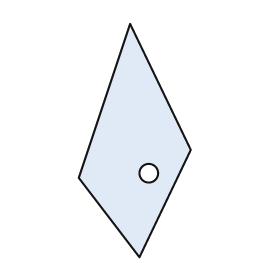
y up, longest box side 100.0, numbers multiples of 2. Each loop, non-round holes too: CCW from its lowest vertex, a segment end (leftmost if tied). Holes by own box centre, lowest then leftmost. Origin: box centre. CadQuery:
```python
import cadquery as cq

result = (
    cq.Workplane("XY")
    .moveTo(2.0, -50.0)
    .lineTo(24.0, -4.0)
    .lineTo(-2.0, 50.0)
    .lineTo(-24.0, -16.0)
    .close()
    .moveTo(6.0, -14.0)
    .circle(4.0)
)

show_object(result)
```